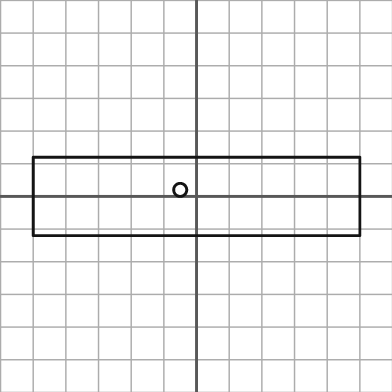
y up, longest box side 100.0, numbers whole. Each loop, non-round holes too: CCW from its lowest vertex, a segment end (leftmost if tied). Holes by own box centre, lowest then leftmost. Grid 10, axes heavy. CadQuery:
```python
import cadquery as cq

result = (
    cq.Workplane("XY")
    .moveTo(-50.0, -12.0)
    .lineTo(50.0, -12.0)
    .lineTo(50.0, 12.0)
    .lineTo(-50.0, 12.0)
    .close()
    .moveTo(-5.0, 2.0)
    .circle(2.0)
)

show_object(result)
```